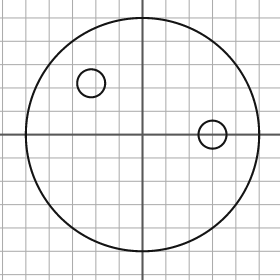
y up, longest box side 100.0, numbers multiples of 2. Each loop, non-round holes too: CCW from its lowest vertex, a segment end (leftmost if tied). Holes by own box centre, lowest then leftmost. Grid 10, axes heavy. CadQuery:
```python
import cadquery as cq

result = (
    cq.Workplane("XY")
    .moveTo(0.0, 0.0)
    .circle(50.0)
    .moveTo(30.0, 0.0)
    .circle(6.0)
    .moveTo(-22.0, 22.0)
    .circle(6.0)
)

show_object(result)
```